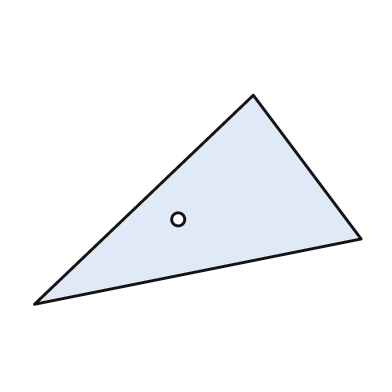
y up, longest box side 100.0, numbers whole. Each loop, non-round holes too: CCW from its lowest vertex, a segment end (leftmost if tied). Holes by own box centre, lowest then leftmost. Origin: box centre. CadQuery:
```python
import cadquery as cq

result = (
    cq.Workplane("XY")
    .moveTo(-50.0, -32.0)
    .lineTo(50.0, -12.0)
    .lineTo(17.0, 32.0)
    .close()
    .moveTo(-6.0, -6.0)
    .circle(2.0)
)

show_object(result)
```